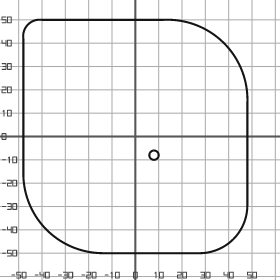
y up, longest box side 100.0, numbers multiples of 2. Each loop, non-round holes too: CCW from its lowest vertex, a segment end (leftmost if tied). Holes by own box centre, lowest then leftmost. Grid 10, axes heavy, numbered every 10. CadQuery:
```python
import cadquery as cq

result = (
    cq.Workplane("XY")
    .moveTo(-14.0, -50.0)
    .lineTo(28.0, -50.0)
    .threePointArc((42.0, -44.0), (48.0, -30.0))
    .lineTo(48.0, 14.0)
    .threePointArc((38.0, 40.0), (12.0, 50.0))
    .lineTo(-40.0, 50.0)
    .threePointArc((-46.0, 48.0), (-48.0, 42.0))
    .lineTo(-48.0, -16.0)
    .threePointArc((-38.0, -40.0), (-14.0, -50.0))
    .close()
    .moveTo(8.0, -8.0)
    .circle(2.0)
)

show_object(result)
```